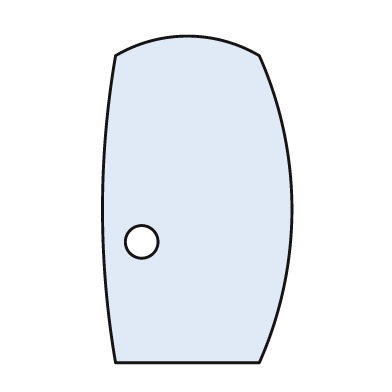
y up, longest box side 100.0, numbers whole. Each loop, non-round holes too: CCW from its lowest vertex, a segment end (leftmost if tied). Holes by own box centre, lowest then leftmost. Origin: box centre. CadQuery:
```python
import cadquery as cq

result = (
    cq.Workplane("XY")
    .moveTo(-25.0, -50.0)
    .lineTo(19.0, -50.0)
    .threePointArc((29.0, -3.0), (19.0, 44.0))
    .threePointArc((-3.0, 50.0), (-25.0, 44.0))
    .threePointArc((-29.0, -3.0), (-25.0, -50.0))
    .close()
    .moveTo(-17.0, -13.0)
    .circle(5.0)
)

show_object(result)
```